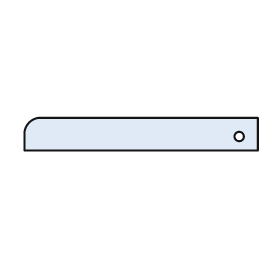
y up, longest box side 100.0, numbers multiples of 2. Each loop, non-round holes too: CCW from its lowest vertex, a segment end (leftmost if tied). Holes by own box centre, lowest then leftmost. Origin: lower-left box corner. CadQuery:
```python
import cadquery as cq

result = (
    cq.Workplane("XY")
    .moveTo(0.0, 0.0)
    .lineTo(100.0, 0.0)
    .lineTo(100.0, 14.0)
    .lineTo(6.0, 14.0)
    .threePointArc((2.0, 12.0), (0.0, 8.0))
    .close()
    .moveTo(92.0, 6.0)
    .circle(2.0)
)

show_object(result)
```